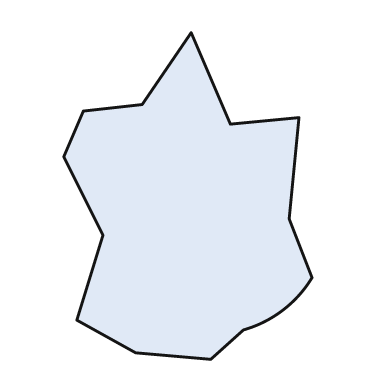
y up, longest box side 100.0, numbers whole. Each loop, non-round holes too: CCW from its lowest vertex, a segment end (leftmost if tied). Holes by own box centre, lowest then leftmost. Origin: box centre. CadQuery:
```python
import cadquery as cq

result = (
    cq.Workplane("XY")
    .moveTo(7.0, -50.0)
    .lineTo(17.0, -41.0)
    .threePointArc((29.0, -35.0), (38.0, -25.0))
    .lineTo(31.0, -7.0)
    .lineTo(34.0, 24.0)
    .lineTo(13.0, 22.0)
    .lineTo(1.0, 50.0)
    .lineTo(-14.0, 28.0)
    .lineTo(-32.0, 26.0)
    .lineTo(-38.0, 12.0)
    .lineTo(-26.0, -12.0)
    .lineTo(-34.0, -38.0)
    .lineTo(-16.0, -48.0)
    .close()
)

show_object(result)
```